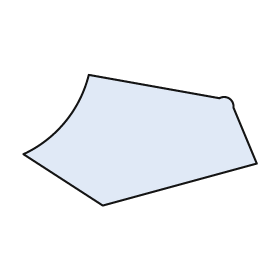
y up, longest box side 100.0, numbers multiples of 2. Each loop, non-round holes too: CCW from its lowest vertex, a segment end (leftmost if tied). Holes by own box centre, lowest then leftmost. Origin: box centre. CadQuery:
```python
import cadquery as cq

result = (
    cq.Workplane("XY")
    .moveTo(-16.0, -28.0)
    .lineTo(50.0, -10.0)
    .lineTo(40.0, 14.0)
    .threePointArc((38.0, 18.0), (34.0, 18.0))
    .lineTo(-22.0, 28.0)
    .threePointArc((-32.0, 8.0), (-50.0, -6.0))
    .close()
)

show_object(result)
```